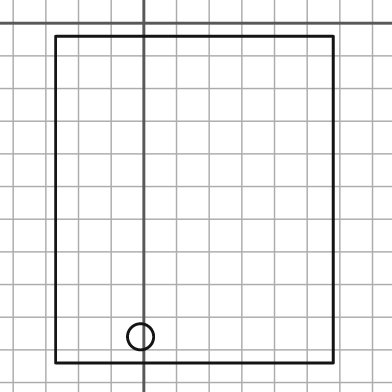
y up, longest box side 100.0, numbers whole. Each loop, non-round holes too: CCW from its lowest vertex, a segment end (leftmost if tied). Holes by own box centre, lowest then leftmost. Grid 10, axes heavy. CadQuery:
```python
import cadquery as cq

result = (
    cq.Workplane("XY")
    .moveTo(-27.0, -104.0)
    .lineTo(58.0, -104.0)
    .lineTo(58.0, -4.0)
    .lineTo(-27.0, -4.0)
    .close()
    .moveTo(-1.0, -96.0)
    .circle(4.0)
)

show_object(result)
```